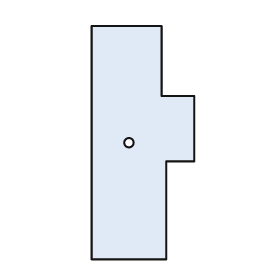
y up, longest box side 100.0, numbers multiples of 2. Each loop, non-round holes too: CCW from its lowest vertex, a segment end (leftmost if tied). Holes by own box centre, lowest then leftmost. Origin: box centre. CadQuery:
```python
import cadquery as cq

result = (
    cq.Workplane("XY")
    .moveTo(-22.0, -50.0)
    .lineTo(10.0, -50.0)
    .lineTo(10.0, -8.0)
    .lineTo(22.0, -8.0)
    .lineTo(22.0, 20.0)
    .lineTo(8.0, 20.0)
    .lineTo(8.0, 50.0)
    .lineTo(-22.0, 50.0)
    .close()
    .moveTo(-6.0, 0.0)
    .circle(2.0)
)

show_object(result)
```